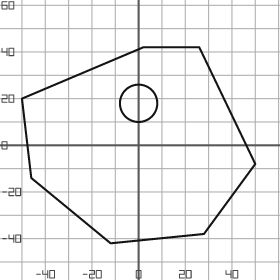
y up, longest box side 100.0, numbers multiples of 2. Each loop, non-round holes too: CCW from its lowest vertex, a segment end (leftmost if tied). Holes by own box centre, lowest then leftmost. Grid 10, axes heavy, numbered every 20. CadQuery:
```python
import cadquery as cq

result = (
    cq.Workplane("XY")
    .moveTo(-12.0, -42.0)
    .lineTo(28.0, -38.0)
    .lineTo(50.0, -8.0)
    .lineTo(26.0, 42.0)
    .lineTo(2.0, 42.0)
    .lineTo(-50.0, 20.0)
    .lineTo(-46.0, -14.0)
    .close()
    .moveTo(0.0, 18.0)
    .circle(8.0)
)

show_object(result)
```